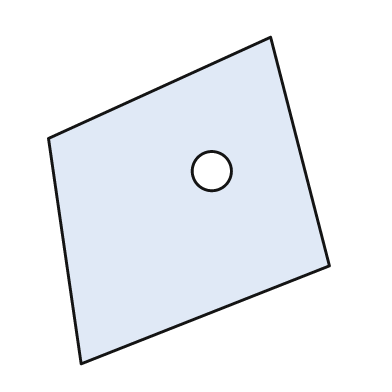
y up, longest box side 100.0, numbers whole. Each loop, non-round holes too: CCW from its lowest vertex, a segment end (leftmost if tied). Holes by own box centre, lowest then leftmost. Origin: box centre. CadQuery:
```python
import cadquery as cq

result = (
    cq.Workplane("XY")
    .moveTo(-33.0, -50.0)
    .lineTo(43.0, -20.0)
    .lineTo(25.0, 50.0)
    .lineTo(-43.0, 19.0)
    .close()
    .moveTo(7.0, 9.0)
    .circle(6.0)
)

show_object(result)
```